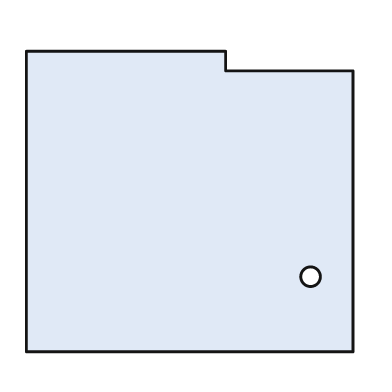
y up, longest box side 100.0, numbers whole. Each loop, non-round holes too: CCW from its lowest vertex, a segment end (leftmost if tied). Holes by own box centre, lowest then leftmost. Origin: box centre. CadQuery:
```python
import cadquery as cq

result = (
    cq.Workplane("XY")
    .moveTo(-50.0, -46.0)
    .lineTo(50.0, -46.0)
    .lineTo(50.0, 40.0)
    .lineTo(11.0, 40.0)
    .lineTo(11.0, 46.0)
    .lineTo(-50.0, 46.0)
    .close()
    .moveTo(37.0, -23.0)
    .circle(3.0)
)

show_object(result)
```